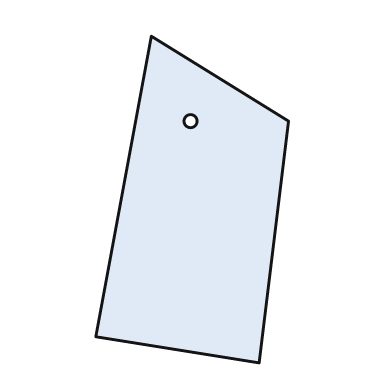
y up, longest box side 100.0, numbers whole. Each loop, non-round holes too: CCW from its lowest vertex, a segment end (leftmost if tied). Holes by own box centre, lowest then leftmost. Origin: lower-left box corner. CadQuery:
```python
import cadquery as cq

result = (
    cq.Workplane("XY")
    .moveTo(50.0, 0.0)
    .lineTo(59.0, 74.0)
    .lineTo(17.0, 100.0)
    .lineTo(0.0, 8.0)
    .close()
    .moveTo(29.0, 74.0)
    .circle(2.0)
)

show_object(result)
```